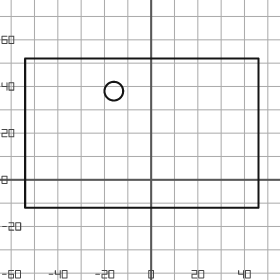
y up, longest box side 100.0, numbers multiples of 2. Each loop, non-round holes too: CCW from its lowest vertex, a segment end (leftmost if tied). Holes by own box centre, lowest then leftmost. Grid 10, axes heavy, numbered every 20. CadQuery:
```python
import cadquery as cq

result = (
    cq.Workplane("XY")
    .moveTo(-54.0, -12.0)
    .lineTo(46.0, -12.0)
    .lineTo(46.0, 52.0)
    .lineTo(-54.0, 52.0)
    .close()
    .moveTo(-16.0, 38.0)
    .circle(4.0)
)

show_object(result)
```